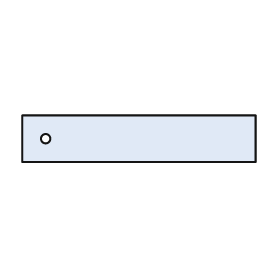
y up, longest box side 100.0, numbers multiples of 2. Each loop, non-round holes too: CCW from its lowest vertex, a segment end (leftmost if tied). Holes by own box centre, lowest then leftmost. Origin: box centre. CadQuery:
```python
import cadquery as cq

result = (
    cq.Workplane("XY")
    .moveTo(-50.0, -10.0)
    .lineTo(50.0, -10.0)
    .lineTo(50.0, 10.0)
    .lineTo(-50.0, 10.0)
    .close()
    .moveTo(-40.0, 0.0)
    .circle(2.0)
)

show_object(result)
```